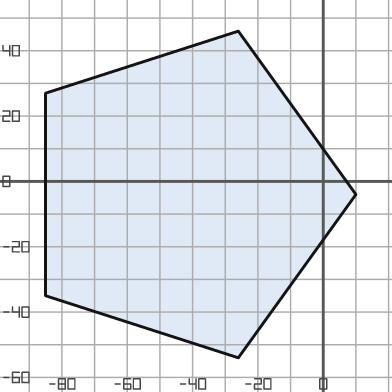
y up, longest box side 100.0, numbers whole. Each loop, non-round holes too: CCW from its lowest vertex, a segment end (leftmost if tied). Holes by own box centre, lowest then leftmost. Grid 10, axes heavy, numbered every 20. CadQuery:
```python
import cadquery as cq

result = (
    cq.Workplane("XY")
    .moveTo(-26.0, -54.0)
    .lineTo(10.0, -4.0)
    .lineTo(-26.0, 46.0)
    .lineTo(-85.0, 27.0)
    .lineTo(-85.0, -35.0)
    .close()
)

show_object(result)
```